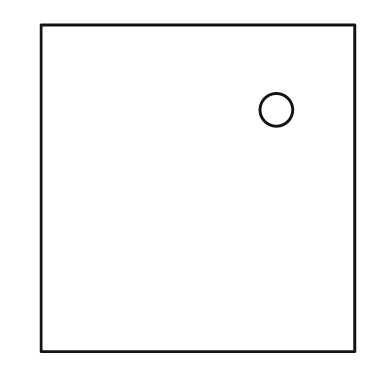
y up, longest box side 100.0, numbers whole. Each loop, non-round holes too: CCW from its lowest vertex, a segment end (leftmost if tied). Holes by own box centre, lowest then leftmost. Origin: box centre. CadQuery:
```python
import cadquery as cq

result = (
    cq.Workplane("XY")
    .moveTo(-48.0, -50.0)
    .lineTo(48.0, -50.0)
    .lineTo(48.0, 50.0)
    .lineTo(-48.0, 50.0)
    .close()
    .moveTo(24.0, 24.0)
    .circle(5.0)
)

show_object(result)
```